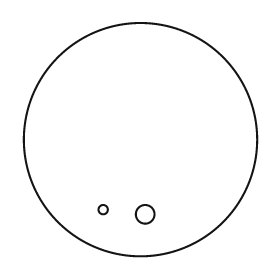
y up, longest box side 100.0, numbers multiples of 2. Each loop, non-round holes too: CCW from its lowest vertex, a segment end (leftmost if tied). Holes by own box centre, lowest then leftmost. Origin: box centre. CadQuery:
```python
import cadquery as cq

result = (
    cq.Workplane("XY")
    .moveTo(0.0, 0.0)
    .circle(50.0)
    .moveTo(2.0, -32.0)
    .circle(4.0)
    .moveTo(-16.0, -30.0)
    .circle(2.0)
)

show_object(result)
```